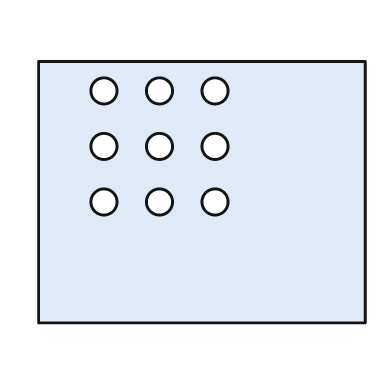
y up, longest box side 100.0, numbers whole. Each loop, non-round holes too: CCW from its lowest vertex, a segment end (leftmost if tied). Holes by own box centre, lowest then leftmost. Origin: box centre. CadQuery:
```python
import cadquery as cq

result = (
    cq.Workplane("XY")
    .moveTo(-50.0, -40.0)
    .lineTo(50.0, -40.0)
    .lineTo(50.0, 40.0)
    .lineTo(-50.0, 40.0)
    .close()
    .moveTo(-30.0, -3.0)
    .circle(4.0)
    .moveTo(-13.0, -3.0)
    .circle(4.0)
    .moveTo(4.0, -3.0)
    .circle(4.0)
    .moveTo(-30.0, 14.0)
    .circle(4.0)
    .moveTo(-13.0, 14.0)
    .circle(4.0)
    .moveTo(4.0, 14.0)
    .circle(4.0)
    .moveTo(-30.0, 31.0)
    .circle(4.0)
    .moveTo(-13.0, 31.0)
    .circle(4.0)
    .moveTo(4.0, 31.0)
    .circle(4.0)
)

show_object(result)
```